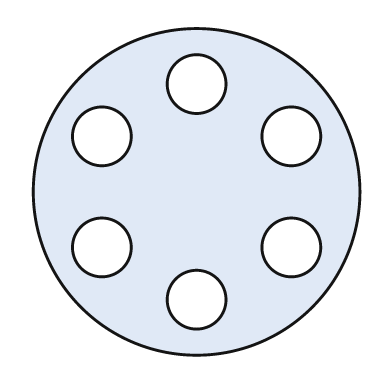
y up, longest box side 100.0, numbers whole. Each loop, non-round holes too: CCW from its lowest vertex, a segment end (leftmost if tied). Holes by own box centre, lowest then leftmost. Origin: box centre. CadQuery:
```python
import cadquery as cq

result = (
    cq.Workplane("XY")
    .moveTo(0.0, 0.0)
    .circle(50.0)
    .moveTo(0.0, -33.0)
    .circle(9.0)
    .moveTo(-29.0, -17.0)
    .circle(9.0)
    .moveTo(29.0, -17.0)
    .circle(9.0)
    .moveTo(-29.0, 17.0)
    .circle(9.0)
    .moveTo(29.0, 17.0)
    .circle(9.0)
    .moveTo(0.0, 33.0)
    .circle(9.0)
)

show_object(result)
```